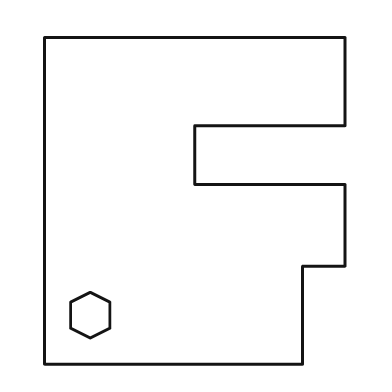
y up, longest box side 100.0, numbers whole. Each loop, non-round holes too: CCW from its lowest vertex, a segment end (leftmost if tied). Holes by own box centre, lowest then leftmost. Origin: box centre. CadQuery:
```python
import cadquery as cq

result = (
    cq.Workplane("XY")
    .moveTo(-46.0, -50.0)
    .lineTo(33.0, -50.0)
    .lineTo(33.0, -20.0)
    .lineTo(46.0, -20.0)
    .lineTo(46.0, 5.0)
    .lineTo(0.0, 5.0)
    .lineTo(0.0, 23.0)
    .lineTo(46.0, 23.0)
    .lineTo(46.0, 50.0)
    .lineTo(-46.0, 50.0)
    .close()
    .moveTo(-32.0, -42.0)
    .lineTo(-26.0, -39.0)
    .lineTo(-26.0, -31.0)
    .lineTo(-32.0, -28.0)
    .lineTo(-38.0, -31.0)
    .lineTo(-38.0, -39.0)
    .close()
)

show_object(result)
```